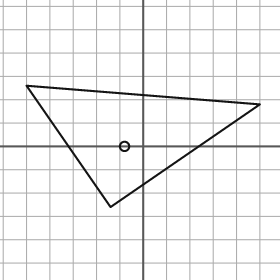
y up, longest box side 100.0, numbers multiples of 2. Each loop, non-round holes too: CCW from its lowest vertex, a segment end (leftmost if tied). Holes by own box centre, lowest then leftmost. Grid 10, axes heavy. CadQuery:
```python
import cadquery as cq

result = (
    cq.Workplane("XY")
    .moveTo(-14.0, -26.0)
    .lineTo(50.0, 18.0)
    .lineTo(-50.0, 26.0)
    .close()
    .moveTo(-8.0, 0.0)
    .circle(2.0)
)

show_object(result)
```